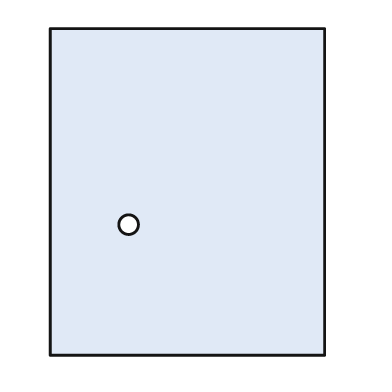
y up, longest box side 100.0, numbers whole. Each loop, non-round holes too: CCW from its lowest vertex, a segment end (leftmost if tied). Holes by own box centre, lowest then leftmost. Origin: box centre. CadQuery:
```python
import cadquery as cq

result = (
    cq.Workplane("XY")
    .moveTo(-42.0, -50.0)
    .lineTo(42.0, -50.0)
    .lineTo(42.0, 50.0)
    .lineTo(-42.0, 50.0)
    .close()
    .moveTo(-18.0, -10.0)
    .circle(3.0)
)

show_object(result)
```